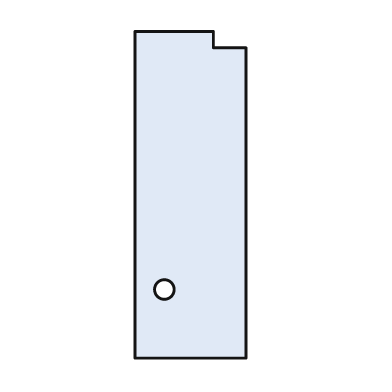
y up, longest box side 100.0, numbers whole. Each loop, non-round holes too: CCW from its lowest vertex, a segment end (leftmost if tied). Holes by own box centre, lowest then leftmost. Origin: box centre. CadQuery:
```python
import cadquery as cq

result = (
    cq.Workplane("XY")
    .moveTo(-17.0, -50.0)
    .lineTo(17.0, -50.0)
    .lineTo(17.0, 45.0)
    .lineTo(7.0, 45.0)
    .lineTo(7.0, 50.0)
    .lineTo(-17.0, 50.0)
    .close()
    .moveTo(-8.0, -29.0)
    .circle(3.0)
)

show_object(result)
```